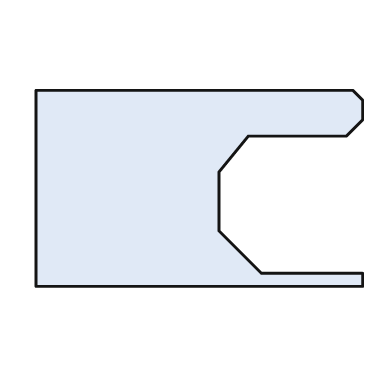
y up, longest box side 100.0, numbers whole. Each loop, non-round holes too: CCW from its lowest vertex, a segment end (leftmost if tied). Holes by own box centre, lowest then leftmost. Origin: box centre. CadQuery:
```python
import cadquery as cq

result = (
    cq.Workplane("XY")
    .moveTo(-50.0, -30.0)
    .lineTo(50.0, -30.0)
    .lineTo(50.0, -26.0)
    .lineTo(19.0, -26.0)
    .lineTo(6.0, -13.0)
    .lineTo(6.0, 5.0)
    .lineTo(15.0, 16.0)
    .lineTo(45.0, 16.0)
    .lineTo(50.0, 21.0)
    .lineTo(50.0, 27.0)
    .lineTo(47.0, 30.0)
    .lineTo(-50.0, 30.0)
    .close()
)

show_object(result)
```